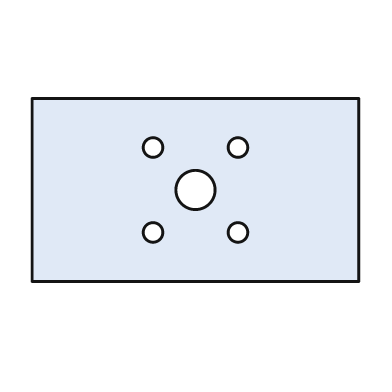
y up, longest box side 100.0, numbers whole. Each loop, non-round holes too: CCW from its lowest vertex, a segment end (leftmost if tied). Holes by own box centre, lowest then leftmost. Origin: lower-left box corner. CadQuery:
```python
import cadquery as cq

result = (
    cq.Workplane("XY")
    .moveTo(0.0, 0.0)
    .lineTo(100.0, 0.0)
    .lineTo(100.0, 56.0)
    .lineTo(0.0, 56.0)
    .close()
    .moveTo(37.0, 15.0)
    .circle(3.0)
    .moveTo(63.0, 15.0)
    .circle(3.0)
    .moveTo(50.0, 28.0)
    .circle(6.0)
    .moveTo(37.0, 41.0)
    .circle(3.0)
    .moveTo(63.0, 41.0)
    .circle(3.0)
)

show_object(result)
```